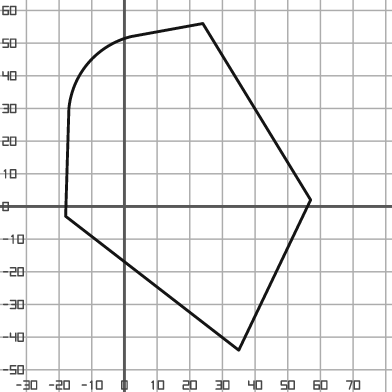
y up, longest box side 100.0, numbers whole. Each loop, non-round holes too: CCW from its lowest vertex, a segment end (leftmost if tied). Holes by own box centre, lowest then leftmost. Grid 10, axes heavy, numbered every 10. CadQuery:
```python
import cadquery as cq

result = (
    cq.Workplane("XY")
    .moveTo(35.0, -44.0)
    .lineTo(57.0, 2.0)
    .lineTo(24.0, 56.0)
    .lineTo(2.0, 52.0)
    .threePointArc((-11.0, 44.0), (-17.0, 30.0))
    .lineTo(-18.0, -3.0)
    .close()
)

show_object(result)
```